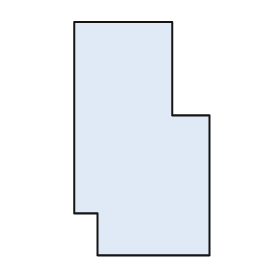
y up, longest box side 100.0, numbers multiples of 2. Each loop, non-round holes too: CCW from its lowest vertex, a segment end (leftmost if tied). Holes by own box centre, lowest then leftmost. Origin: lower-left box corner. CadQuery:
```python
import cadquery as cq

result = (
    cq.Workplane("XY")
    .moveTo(10.0, 0.0)
    .lineTo(58.0, 0.0)
    .lineTo(58.0, 60.0)
    .lineTo(42.0, 60.0)
    .lineTo(42.0, 100.0)
    .lineTo(0.0, 100.0)
    .lineTo(0.0, 18.0)
    .lineTo(10.0, 18.0)
    .close()
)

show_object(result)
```